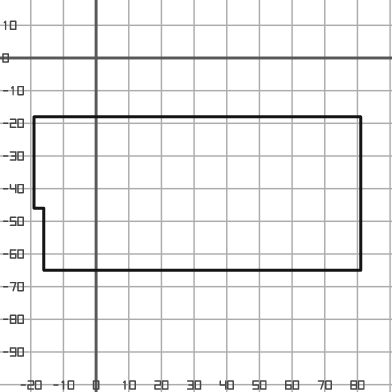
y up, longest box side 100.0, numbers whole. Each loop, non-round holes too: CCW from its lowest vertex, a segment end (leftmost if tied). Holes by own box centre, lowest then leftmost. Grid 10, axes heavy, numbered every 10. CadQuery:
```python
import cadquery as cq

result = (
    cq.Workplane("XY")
    .moveTo(-16.0, -65.0)
    .lineTo(81.0, -65.0)
    .lineTo(81.0, -18.0)
    .lineTo(-19.0, -18.0)
    .lineTo(-19.0, -46.0)
    .lineTo(-16.0, -46.0)
    .close()
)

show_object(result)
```